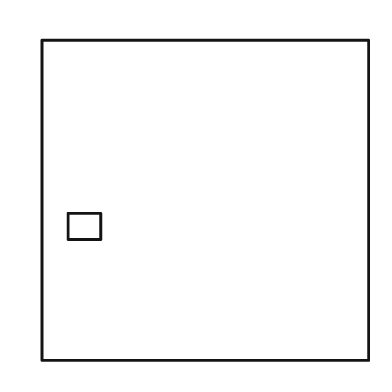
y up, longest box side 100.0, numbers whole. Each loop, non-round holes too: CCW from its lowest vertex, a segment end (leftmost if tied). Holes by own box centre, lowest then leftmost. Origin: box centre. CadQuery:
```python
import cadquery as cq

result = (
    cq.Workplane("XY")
    .moveTo(-50.0, -49.0)
    .lineTo(50.0, -49.0)
    .lineTo(50.0, 49.0)
    .lineTo(-50.0, 49.0)
    .close()
    .moveTo(-42.0, -12.0)
    .lineTo(-32.0, -12.0)
    .lineTo(-32.0, -4.0)
    .lineTo(-42.0, -4.0)
    .close()
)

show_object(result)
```